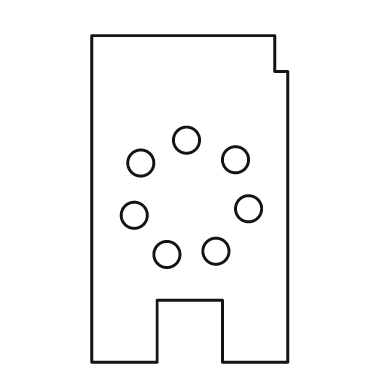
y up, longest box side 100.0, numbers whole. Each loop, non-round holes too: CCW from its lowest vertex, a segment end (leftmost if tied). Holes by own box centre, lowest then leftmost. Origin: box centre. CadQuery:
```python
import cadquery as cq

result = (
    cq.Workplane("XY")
    .moveTo(-30.0, -50.0)
    .lineTo(-10.0, -50.0)
    .lineTo(-10.0, -31.0)
    .lineTo(10.0, -31.0)
    .lineTo(10.0, -50.0)
    .lineTo(30.0, -50.0)
    .lineTo(30.0, 39.0)
    .lineTo(26.0, 39.0)
    .lineTo(26.0, 50.0)
    .lineTo(-30.0, 50.0)
    .close()
    .moveTo(-7.0, -17.0)
    .circle(4.0)
    .moveTo(8.0, -16.0)
    .circle(4.0)
    .moveTo(-17.0, -5.0)
    .circle(4.0)
    .moveTo(18.0, -3.0)
    .circle(4.0)
    .moveTo(-15.0, 11.0)
    .circle(4.0)
    .moveTo(14.0, 12.0)
    .circle(4.0)
    .moveTo(-1.0, 18.0)
    .circle(4.0)
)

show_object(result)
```